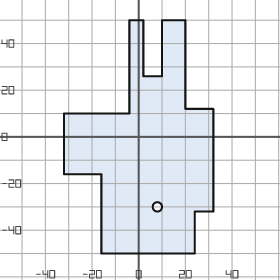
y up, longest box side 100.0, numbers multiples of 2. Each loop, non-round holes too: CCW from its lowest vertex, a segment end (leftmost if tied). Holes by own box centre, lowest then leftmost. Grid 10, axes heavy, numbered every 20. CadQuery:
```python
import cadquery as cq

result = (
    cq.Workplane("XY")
    .moveTo(-16.0, -50.0)
    .lineTo(24.0, -50.0)
    .lineTo(24.0, -32.0)
    .lineTo(32.0, -32.0)
    .lineTo(32.0, 12.0)
    .lineTo(20.0, 12.0)
    .lineTo(20.0, 50.0)
    .lineTo(10.0, 50.0)
    .lineTo(10.0, 26.0)
    .lineTo(2.0, 26.0)
    .lineTo(2.0, 50.0)
    .lineTo(-4.0, 50.0)
    .lineTo(-4.0, 10.0)
    .lineTo(-32.0, 10.0)
    .lineTo(-32.0, -16.0)
    .lineTo(-16.0, -16.0)
    .close()
    .moveTo(8.0, -30.0)
    .circle(2.0)
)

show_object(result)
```